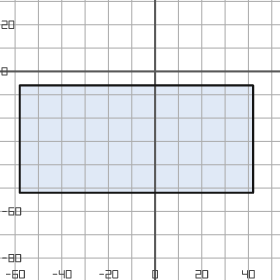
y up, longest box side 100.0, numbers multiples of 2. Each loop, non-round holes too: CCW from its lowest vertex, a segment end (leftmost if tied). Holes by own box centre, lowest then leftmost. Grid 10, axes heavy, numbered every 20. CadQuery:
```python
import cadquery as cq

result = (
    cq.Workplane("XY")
    .moveTo(-58.0, -52.0)
    .lineTo(42.0, -52.0)
    .lineTo(42.0, -6.0)
    .lineTo(-58.0, -6.0)
    .close()
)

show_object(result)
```